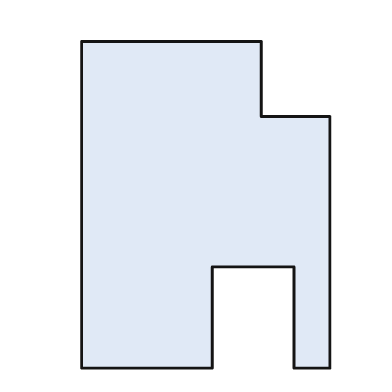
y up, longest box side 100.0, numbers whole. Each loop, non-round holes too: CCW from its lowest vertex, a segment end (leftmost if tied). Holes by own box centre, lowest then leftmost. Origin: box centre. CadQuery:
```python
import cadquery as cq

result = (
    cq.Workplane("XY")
    .moveTo(-38.0, -50.0)
    .lineTo(2.0, -50.0)
    .lineTo(2.0, -19.0)
    .lineTo(27.0, -19.0)
    .lineTo(27.0, -50.0)
    .lineTo(38.0, -50.0)
    .lineTo(38.0, 27.0)
    .lineTo(17.0, 27.0)
    .lineTo(17.0, 50.0)
    .lineTo(-38.0, 50.0)
    .close()
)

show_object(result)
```